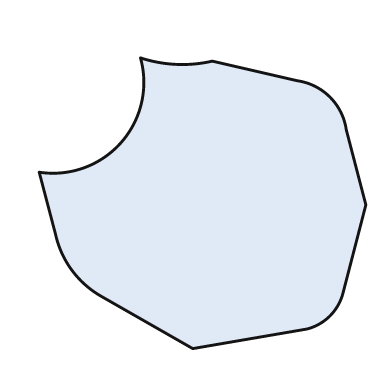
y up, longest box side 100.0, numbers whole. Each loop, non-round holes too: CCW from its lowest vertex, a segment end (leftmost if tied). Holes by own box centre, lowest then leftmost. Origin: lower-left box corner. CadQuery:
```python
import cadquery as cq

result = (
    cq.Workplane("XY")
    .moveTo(47.0, 0.0)
    .lineTo(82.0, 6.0)
    .threePointArc((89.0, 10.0), (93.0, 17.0))
    .lineTo(100.0, 44.0)
    .lineTo(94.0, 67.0)
    .threePointArc((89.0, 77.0), (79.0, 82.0))
    .lineTo(53.0, 88.0)
    .threePointArc((42.0, 87.0), (31.0, 89.0))
    .threePointArc((25.0, 63.0), (0.0, 54.0))
    .lineTo(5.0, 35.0)
    .threePointArc((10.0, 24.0), (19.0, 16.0))
    .close()
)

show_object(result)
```